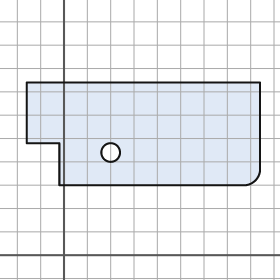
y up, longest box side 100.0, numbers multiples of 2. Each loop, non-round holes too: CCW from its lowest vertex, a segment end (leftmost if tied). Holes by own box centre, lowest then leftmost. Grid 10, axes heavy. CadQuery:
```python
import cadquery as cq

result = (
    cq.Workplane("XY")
    .moveTo(-2.0, 30.0)
    .lineTo(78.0, 30.0)
    .threePointArc((82.0, 32.0), (84.0, 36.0))
    .lineTo(84.0, 74.0)
    .lineTo(-16.0, 74.0)
    .lineTo(-16.0, 48.0)
    .lineTo(-2.0, 48.0)
    .close()
    .moveTo(20.0, 44.0)
    .circle(4.0)
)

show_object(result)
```